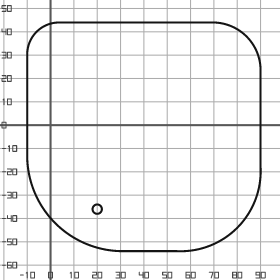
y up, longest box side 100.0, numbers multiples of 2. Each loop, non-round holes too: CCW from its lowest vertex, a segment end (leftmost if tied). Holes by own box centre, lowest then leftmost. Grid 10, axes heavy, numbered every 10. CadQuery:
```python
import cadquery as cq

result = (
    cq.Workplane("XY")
    .moveTo(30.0, -54.0)
    .lineTo(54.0, -54.0)
    .threePointArc((80.0, -44.0), (90.0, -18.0))
    .lineTo(90.0, 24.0)
    .threePointArc((84.0, 38.0), (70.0, 44.0))
    .lineTo(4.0, 44.0)
    .threePointArc((-6.0, 40.0), (-10.0, 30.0))
    .lineTo(-10.0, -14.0)
    .threePointArc((2.0, -42.0), (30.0, -54.0))
    .close()
    .moveTo(20.0, -36.0)
    .circle(2.0)
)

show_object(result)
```